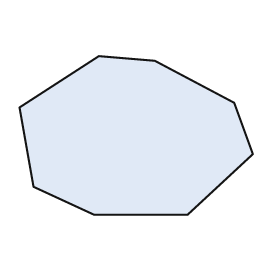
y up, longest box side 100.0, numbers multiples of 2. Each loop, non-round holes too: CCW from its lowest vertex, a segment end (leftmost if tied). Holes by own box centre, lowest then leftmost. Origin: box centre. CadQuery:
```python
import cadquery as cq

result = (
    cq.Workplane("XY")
    .moveTo(-18.0, -34.0)
    .lineTo(22.0, -34.0)
    .lineTo(50.0, -8.0)
    .lineTo(42.0, 14.0)
    .lineTo(8.0, 32.0)
    .lineTo(-16.0, 34.0)
    .lineTo(-50.0, 12.0)
    .lineTo(-44.0, -22.0)
    .close()
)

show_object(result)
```